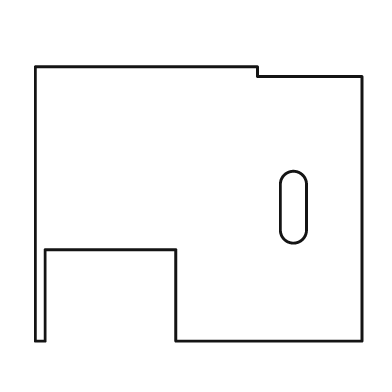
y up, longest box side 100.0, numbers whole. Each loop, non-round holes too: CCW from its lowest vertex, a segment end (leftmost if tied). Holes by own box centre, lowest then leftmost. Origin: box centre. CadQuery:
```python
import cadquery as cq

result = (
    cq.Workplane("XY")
    .moveTo(-50.0, -42.0)
    .lineTo(-47.0, -42.0)
    .lineTo(-47.0, -14.0)
    .lineTo(-7.0, -14.0)
    .lineTo(-7.0, -42.0)
    .lineTo(50.0, -42.0)
    .lineTo(50.0, 39.0)
    .lineTo(18.0, 39.0)
    .lineTo(18.0, 42.0)
    .lineTo(-50.0, 42.0)
    .close()
    .moveTo(25.0, -8.0)
    .threePointArc((29.0, -12.0), (33.0, -8.0))
    .lineTo(33.0, 6.0)
    .threePointArc((29.0, 10.0), (25.0, 6.0))
    .close()
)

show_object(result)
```